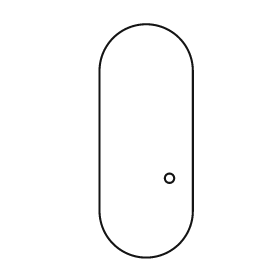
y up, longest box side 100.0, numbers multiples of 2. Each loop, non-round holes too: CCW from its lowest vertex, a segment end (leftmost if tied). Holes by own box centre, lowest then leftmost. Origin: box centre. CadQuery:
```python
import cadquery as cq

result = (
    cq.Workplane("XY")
    .moveTo(-20.0, -30.0)
    .threePointArc((0.0, -50.0), (20.0, -30.0))
    .lineTo(20.0, 30.0)
    .threePointArc((0.0, 50.0), (-20.0, 30.0))
    .close()
    .moveTo(10.0, -16.0)
    .circle(2.0)
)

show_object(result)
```